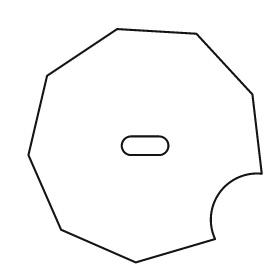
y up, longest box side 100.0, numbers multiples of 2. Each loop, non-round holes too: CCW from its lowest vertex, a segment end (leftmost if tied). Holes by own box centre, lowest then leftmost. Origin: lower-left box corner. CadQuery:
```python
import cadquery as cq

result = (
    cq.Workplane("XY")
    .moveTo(46.0, 0.0)
    .lineTo(80.0, 10.0)
    .threePointArc((82.0, 30.0), (100.0, 38.0))
    .lineTo(96.0, 72.0)
    .lineTo(72.0, 98.0)
    .lineTo(38.0, 100.0)
    .lineTo(8.0, 80.0)
    .lineTo(0.0, 46.0)
    .lineTo(14.0, 14.0)
    .close()
    .moveTo(44.0, 46.0)
    .lineTo(56.0, 46.0)
    .threePointArc((60.0, 50.0), (56.0, 54.0))
    .lineTo(44.0, 54.0)
    .threePointArc((40.0, 50.0), (44.0, 46.0))
    .close()
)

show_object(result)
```